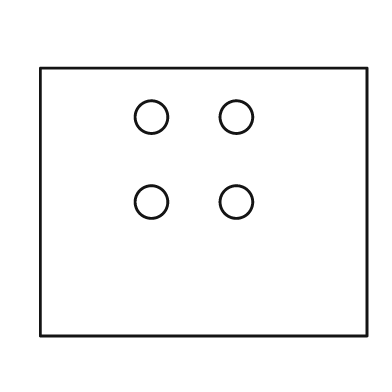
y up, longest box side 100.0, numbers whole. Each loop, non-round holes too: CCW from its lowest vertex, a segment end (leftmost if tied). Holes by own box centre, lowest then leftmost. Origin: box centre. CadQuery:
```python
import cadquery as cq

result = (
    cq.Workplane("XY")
    .moveTo(-50.0, -41.0)
    .lineTo(50.0, -41.0)
    .lineTo(50.0, 41.0)
    .lineTo(-50.0, 41.0)
    .close()
    .moveTo(-16.0, 0.0)
    .circle(5.0)
    .moveTo(10.0, 0.0)
    .circle(5.0)
    .moveTo(-16.0, 26.0)
    .circle(5.0)
    .moveTo(10.0, 26.0)
    .circle(5.0)
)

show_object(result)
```